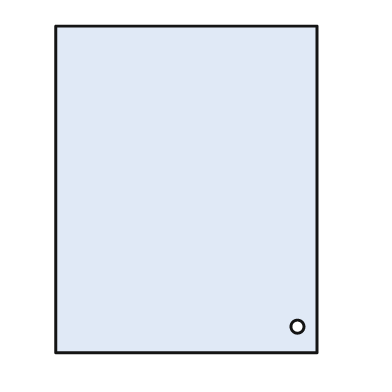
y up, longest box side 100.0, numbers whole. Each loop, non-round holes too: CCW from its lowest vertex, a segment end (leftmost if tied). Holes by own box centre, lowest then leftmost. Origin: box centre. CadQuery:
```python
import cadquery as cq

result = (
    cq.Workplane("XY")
    .moveTo(-40.0, -50.0)
    .lineTo(40.0, -50.0)
    .lineTo(40.0, 50.0)
    .lineTo(-40.0, 50.0)
    .close()
    .moveTo(34.0, -42.0)
    .circle(2.0)
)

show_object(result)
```